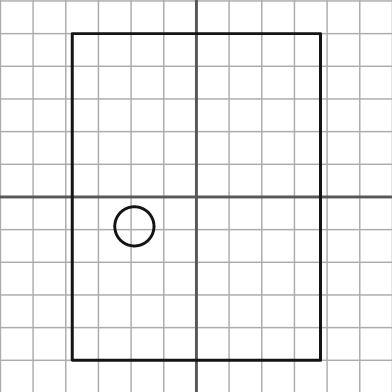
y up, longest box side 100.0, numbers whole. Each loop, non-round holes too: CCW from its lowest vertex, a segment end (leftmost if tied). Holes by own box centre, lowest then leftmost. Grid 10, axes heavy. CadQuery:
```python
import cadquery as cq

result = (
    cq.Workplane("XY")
    .moveTo(-38.0, -50.0)
    .lineTo(38.0, -50.0)
    .lineTo(38.0, 50.0)
    .lineTo(-38.0, 50.0)
    .close()
    .moveTo(-19.0, -9.0)
    .circle(6.0)
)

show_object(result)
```